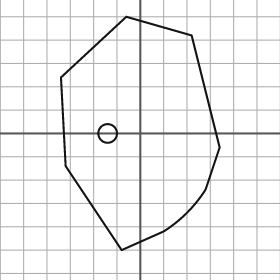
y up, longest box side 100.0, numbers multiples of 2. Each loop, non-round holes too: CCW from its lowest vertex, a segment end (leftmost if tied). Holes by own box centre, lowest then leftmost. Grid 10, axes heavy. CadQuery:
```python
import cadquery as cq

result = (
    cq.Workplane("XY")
    .moveTo(-8.0, -50.0)
    .lineTo(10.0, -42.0)
    .threePointArc((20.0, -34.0), (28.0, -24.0))
    .lineTo(34.0, -6.0)
    .lineTo(22.0, 42.0)
    .lineTo(-6.0, 50.0)
    .lineTo(-34.0, 24.0)
    .lineTo(-32.0, -14.0)
    .close()
    .moveTo(-14.0, 0.0)
    .circle(4.0)
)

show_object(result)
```